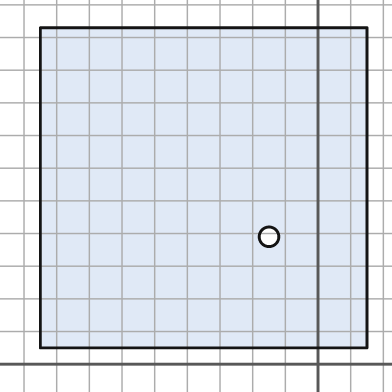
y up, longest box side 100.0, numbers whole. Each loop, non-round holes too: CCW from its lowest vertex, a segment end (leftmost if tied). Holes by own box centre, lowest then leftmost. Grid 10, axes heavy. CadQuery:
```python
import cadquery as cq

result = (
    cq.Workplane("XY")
    .moveTo(-85.0, 5.0)
    .lineTo(15.0, 5.0)
    .lineTo(15.0, 103.0)
    .lineTo(-85.0, 103.0)
    .close()
    .moveTo(-15.0, 39.0)
    .circle(3.0)
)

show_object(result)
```